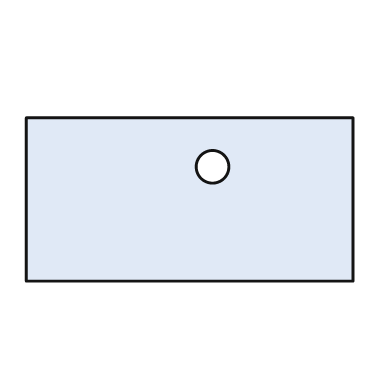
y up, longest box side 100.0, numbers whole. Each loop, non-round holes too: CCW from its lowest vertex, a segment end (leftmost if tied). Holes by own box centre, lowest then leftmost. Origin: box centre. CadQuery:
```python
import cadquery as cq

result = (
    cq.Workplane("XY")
    .moveTo(-50.0, -25.0)
    .lineTo(50.0, -25.0)
    .lineTo(50.0, 25.0)
    .lineTo(-50.0, 25.0)
    .close()
    .moveTo(7.0, 10.0)
    .circle(5.0)
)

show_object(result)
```